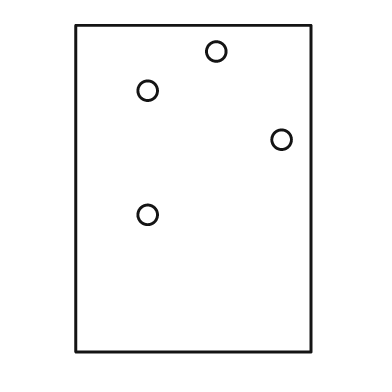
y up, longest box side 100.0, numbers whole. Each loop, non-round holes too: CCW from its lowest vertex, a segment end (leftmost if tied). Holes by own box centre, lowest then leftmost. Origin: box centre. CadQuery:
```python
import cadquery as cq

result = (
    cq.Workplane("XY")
    .moveTo(-36.0, -50.0)
    .lineTo(36.0, -50.0)
    .lineTo(36.0, 50.0)
    .lineTo(-36.0, 50.0)
    .close()
    .moveTo(-14.0, -8.0)
    .circle(3.0)
    .moveTo(27.0, 15.0)
    .circle(3.0)
    .moveTo(-14.0, 30.0)
    .circle(3.0)
    .moveTo(7.0, 42.0)
    .circle(3.0)
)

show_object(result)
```